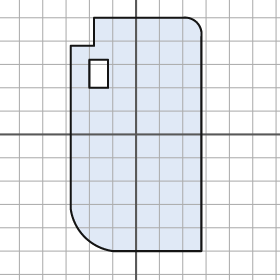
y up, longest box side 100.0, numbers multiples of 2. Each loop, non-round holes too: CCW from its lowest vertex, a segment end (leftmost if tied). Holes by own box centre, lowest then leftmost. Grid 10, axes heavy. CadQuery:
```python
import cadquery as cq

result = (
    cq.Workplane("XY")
    .moveTo(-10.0, -50.0)
    .lineTo(28.0, -50.0)
    .lineTo(28.0, 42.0)
    .threePointArc((26.0, 48.0), (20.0, 50.0))
    .lineTo(-18.0, 50.0)
    .lineTo(-18.0, 38.0)
    .lineTo(-28.0, 38.0)
    .lineTo(-28.0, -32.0)
    .threePointArc((-22.0, -44.0), (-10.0, -50.0))
    .close()
    .moveTo(-20.0, 20.0)
    .lineTo(-12.0, 20.0)
    .lineTo(-12.0, 32.0)
    .lineTo(-20.0, 32.0)
    .close()
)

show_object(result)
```